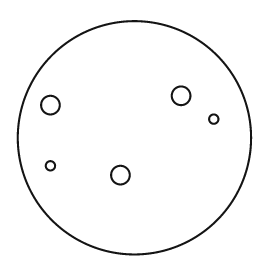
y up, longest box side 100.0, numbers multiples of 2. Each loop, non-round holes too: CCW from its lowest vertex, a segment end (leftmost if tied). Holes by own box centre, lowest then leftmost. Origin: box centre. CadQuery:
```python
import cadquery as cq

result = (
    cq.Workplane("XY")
    .moveTo(0.0, 0.0)
    .circle(50.0)
    .moveTo(-6.0, -16.0)
    .circle(4.0)
    .moveTo(-36.0, -12.0)
    .circle(2.0)
    .moveTo(34.0, 8.0)
    .circle(2.0)
    .moveTo(-36.0, 14.0)
    .circle(4.0)
    .moveTo(20.0, 18.0)
    .circle(4.0)
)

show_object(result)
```